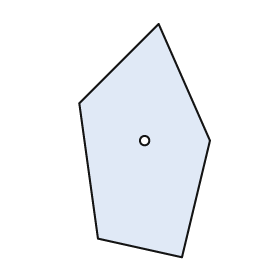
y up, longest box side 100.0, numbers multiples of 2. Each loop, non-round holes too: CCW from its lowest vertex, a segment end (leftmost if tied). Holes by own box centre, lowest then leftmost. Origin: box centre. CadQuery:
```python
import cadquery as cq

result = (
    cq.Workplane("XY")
    .moveTo(16.0, -50.0)
    .lineTo(28.0, 0.0)
    .lineTo(6.0, 50.0)
    .lineTo(-28.0, 16.0)
    .lineTo(-20.0, -42.0)
    .close()
    .moveTo(0.0, 0.0)
    .circle(2.0)
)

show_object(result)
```